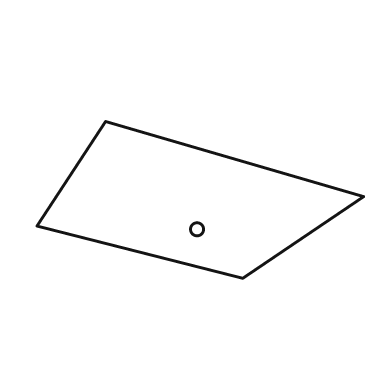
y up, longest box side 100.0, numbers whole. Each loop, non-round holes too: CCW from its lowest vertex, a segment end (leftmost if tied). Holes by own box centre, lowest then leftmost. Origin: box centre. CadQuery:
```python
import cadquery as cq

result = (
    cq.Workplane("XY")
    .moveTo(13.0, -24.0)
    .lineTo(50.0, 1.0)
    .lineTo(-29.0, 24.0)
    .lineTo(-50.0, -8.0)
    .close()
    .moveTo(-1.0, -9.0)
    .circle(2.0)
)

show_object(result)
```